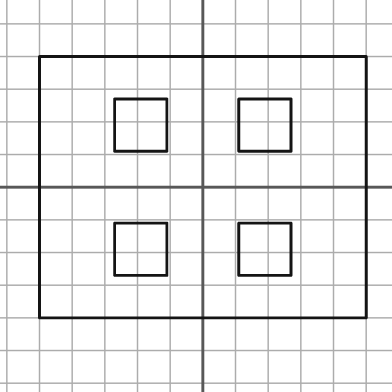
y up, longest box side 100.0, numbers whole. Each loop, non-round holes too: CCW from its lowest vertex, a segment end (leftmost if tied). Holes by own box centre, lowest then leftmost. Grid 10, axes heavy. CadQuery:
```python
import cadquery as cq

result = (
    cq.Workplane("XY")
    .moveTo(-50.0, -40.0)
    .lineTo(50.0, -40.0)
    .lineTo(50.0, 40.0)
    .lineTo(-50.0, 40.0)
    .close()
    .moveTo(-27.0, -27.0)
    .lineTo(-11.0, -27.0)
    .lineTo(-11.0, -11.0)
    .lineTo(-27.0, -11.0)
    .close()
    .moveTo(11.0, -27.0)
    .lineTo(27.0, -27.0)
    .lineTo(27.0, -11.0)
    .lineTo(11.0, -11.0)
    .close()
    .moveTo(-27.0, 11.0)
    .lineTo(-11.0, 11.0)
    .lineTo(-11.0, 27.0)
    .lineTo(-27.0, 27.0)
    .close()
    .moveTo(11.0, 11.0)
    .lineTo(27.0, 11.0)
    .lineTo(27.0, 27.0)
    .lineTo(11.0, 27.0)
    .close()
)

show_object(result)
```